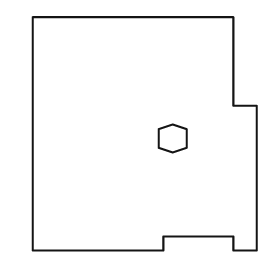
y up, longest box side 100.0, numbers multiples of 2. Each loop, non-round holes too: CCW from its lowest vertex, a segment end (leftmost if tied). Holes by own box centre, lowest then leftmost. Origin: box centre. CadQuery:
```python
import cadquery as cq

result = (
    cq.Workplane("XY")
    .moveTo(-48.0, -50.0)
    .lineTo(8.0, -50.0)
    .lineTo(8.0, -44.0)
    .lineTo(38.0, -44.0)
    .lineTo(38.0, -50.0)
    .lineTo(48.0, -50.0)
    .lineTo(48.0, 12.0)
    .lineTo(38.0, 12.0)
    .lineTo(38.0, 50.0)
    .lineTo(-48.0, 50.0)
    .close()
    .moveTo(12.0, -8.0)
    .lineTo(18.0, -6.0)
    .lineTo(18.0, 2.0)
    .lineTo(12.0, 4.0)
    .lineTo(6.0, 2.0)
    .lineTo(6.0, -6.0)
    .close()
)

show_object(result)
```